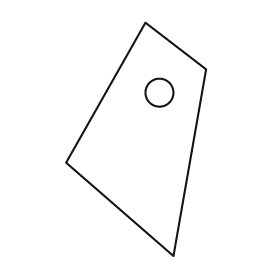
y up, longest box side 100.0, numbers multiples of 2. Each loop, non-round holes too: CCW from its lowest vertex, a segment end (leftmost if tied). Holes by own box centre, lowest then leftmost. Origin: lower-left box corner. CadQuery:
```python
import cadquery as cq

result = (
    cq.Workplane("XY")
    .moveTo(46.0, 0.0)
    .lineTo(60.0, 80.0)
    .lineTo(34.0, 100.0)
    .lineTo(0.0, 40.0)
    .close()
    .moveTo(40.0, 70.0)
    .circle(6.0)
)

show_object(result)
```